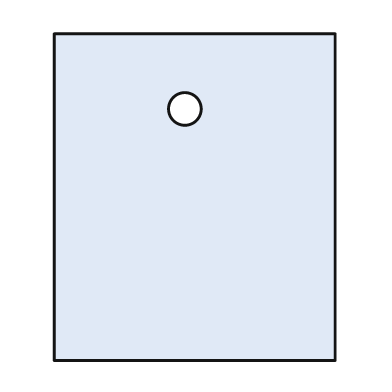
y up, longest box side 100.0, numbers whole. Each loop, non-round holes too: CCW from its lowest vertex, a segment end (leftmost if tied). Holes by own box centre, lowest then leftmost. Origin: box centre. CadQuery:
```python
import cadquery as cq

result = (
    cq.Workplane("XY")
    .moveTo(-43.0, -50.0)
    .lineTo(43.0, -50.0)
    .lineTo(43.0, 50.0)
    .lineTo(-43.0, 50.0)
    .close()
    .moveTo(-3.0, 27.0)
    .circle(5.0)
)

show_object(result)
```